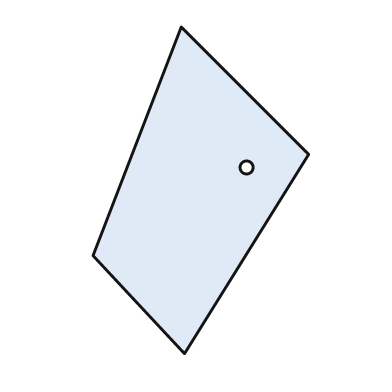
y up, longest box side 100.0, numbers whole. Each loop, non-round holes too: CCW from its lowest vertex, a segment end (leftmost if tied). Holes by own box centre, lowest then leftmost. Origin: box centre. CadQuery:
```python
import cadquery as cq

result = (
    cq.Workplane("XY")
    .moveTo(-5.0, -50.0)
    .lineTo(33.0, 11.0)
    .lineTo(-6.0, 50.0)
    .lineTo(-33.0, -20.0)
    .close()
    .moveTo(14.0, 7.0)
    .circle(2.0)
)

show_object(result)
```